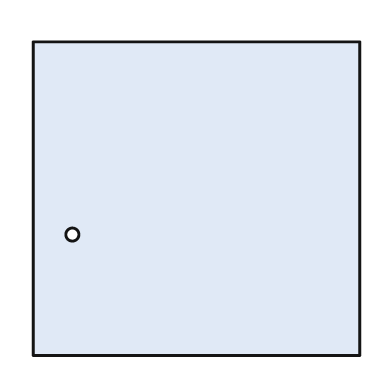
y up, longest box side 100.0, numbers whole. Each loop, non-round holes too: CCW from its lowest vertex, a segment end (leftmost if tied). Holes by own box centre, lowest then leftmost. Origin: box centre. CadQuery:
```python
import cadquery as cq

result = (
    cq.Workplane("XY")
    .moveTo(-50.0, -48.0)
    .lineTo(50.0, -48.0)
    .lineTo(50.0, 48.0)
    .lineTo(-50.0, 48.0)
    .close()
    .moveTo(-38.0, -11.0)
    .circle(2.0)
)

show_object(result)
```